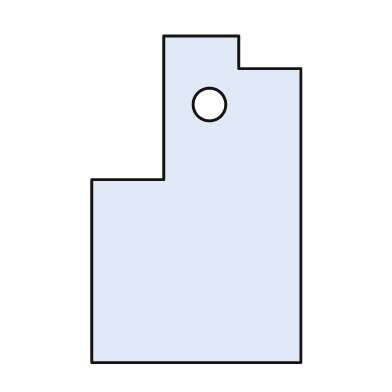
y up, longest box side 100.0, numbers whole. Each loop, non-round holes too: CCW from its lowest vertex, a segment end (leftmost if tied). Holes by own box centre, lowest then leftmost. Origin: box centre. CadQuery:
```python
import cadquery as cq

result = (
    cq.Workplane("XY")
    .moveTo(-32.0, -50.0)
    .lineTo(32.0, -50.0)
    .lineTo(32.0, 40.0)
    .lineTo(13.0, 40.0)
    .lineTo(13.0, 50.0)
    .lineTo(-10.0, 50.0)
    .lineTo(-10.0, 6.0)
    .lineTo(-32.0, 6.0)
    .close()
    .moveTo(4.0, 29.0)
    .circle(5.0)
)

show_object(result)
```